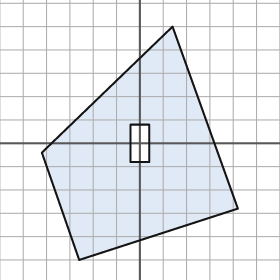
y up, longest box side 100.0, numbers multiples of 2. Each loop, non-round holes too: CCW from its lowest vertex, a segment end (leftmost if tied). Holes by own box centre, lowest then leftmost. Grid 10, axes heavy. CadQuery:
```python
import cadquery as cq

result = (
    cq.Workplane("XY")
    .moveTo(-26.0, -50.0)
    .lineTo(42.0, -28.0)
    .lineTo(14.0, 50.0)
    .lineTo(-42.0, -4.0)
    .close()
    .moveTo(-4.0, -8.0)
    .lineTo(4.0, -8.0)
    .lineTo(4.0, 8.0)
    .lineTo(-4.0, 8.0)
    .close()
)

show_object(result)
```